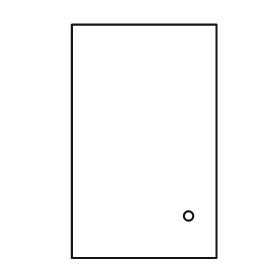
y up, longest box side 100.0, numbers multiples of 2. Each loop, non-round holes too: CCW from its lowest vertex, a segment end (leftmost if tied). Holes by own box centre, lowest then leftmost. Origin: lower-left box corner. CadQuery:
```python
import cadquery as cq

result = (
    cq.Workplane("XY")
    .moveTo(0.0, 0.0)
    .lineTo(62.0, 0.0)
    .lineTo(62.0, 100.0)
    .lineTo(0.0, 100.0)
    .close()
    .moveTo(50.0, 18.0)
    .circle(2.0)
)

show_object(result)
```